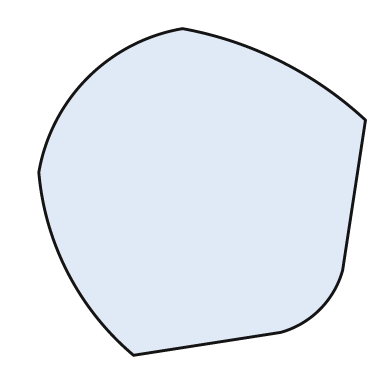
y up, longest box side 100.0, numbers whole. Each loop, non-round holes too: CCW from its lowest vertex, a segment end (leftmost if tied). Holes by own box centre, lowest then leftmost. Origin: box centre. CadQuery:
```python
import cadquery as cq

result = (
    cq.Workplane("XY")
    .moveTo(-21.0, -50.0)
    .lineTo(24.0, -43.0)
    .threePointArc((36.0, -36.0), (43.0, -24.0))
    .lineTo(50.0, 22.0)
    .threePointArc((24.0, 40.0), (-6.0, 50.0))
    .threePointArc((-35.0, 35.0), (-50.0, 6.0))
    .threePointArc((-41.0, -25.0), (-21.0, -50.0))
    .close()
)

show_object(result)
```